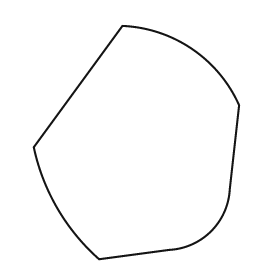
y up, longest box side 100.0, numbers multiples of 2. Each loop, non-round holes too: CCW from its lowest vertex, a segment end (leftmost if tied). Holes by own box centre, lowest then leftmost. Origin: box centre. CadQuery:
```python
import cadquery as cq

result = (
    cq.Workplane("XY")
    .moveTo(-16.0, -50.0)
    .lineTo(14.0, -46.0)
    .threePointArc((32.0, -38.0), (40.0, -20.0))
    .lineTo(44.0, 16.0)
    .threePointArc((24.0, 40.0), (-6.0, 50.0))
    .lineTo(-44.0, -2.0)
    .threePointArc((-34.0, -28.0), (-16.0, -50.0))
    .close()
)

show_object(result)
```